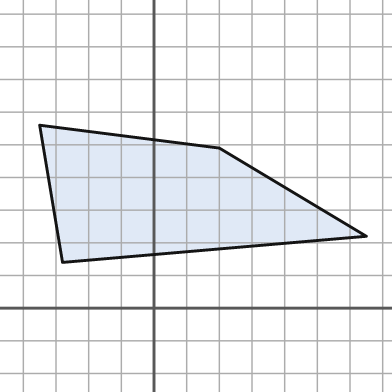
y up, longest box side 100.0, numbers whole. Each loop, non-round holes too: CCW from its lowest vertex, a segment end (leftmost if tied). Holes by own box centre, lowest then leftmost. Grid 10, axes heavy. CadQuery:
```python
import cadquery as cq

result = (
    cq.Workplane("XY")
    .moveTo(-28.0, 14.0)
    .lineTo(65.0, 22.0)
    .lineTo(20.0, 49.0)
    .lineTo(-35.0, 56.0)
    .close()
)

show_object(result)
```